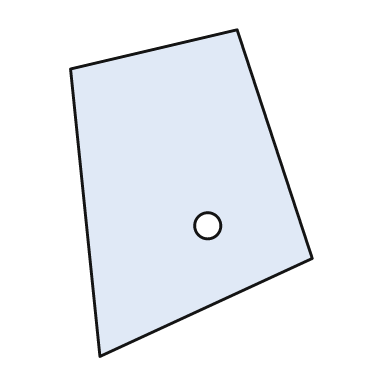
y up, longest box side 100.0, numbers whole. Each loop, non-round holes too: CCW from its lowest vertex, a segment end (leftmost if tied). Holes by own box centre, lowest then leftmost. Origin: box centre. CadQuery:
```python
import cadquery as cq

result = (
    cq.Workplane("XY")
    .moveTo(-28.0, -50.0)
    .lineTo(37.0, -20.0)
    .lineTo(14.0, 50.0)
    .lineTo(-37.0, 38.0)
    .close()
    .moveTo(5.0, -10.0)
    .circle(4.0)
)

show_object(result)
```